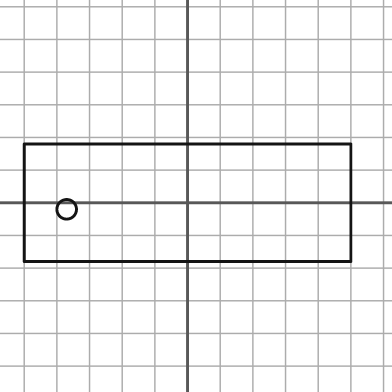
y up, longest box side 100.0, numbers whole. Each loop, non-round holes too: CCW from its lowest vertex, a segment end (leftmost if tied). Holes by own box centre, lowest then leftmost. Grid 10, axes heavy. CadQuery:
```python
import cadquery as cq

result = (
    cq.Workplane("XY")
    .moveTo(-50.0, -18.0)
    .lineTo(50.0, -18.0)
    .lineTo(50.0, 18.0)
    .lineTo(-50.0, 18.0)
    .close()
    .moveTo(-37.0, -2.0)
    .circle(3.0)
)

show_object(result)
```